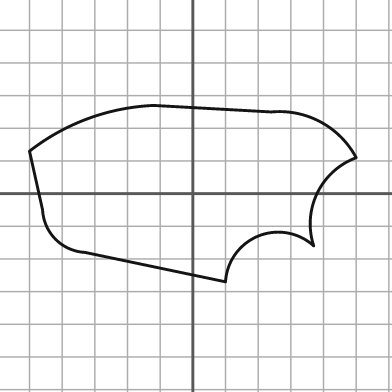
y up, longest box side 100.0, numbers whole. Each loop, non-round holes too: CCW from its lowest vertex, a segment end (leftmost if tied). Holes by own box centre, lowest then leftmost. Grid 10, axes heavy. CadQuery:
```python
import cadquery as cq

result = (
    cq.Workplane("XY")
    .moveTo(10.0, -27.0)
    .threePointArc((20.0, -13.0), (37.0, -16.0))
    .threePointArc((38.0, 0.0), (50.0, 11.0))
    .threePointArc((39.0, 22.0), (24.0, 25.0))
    .lineTo(-12.0, 27.0)
    .threePointArc((-32.0, 23.0), (-50.0, 13.0))
    .lineTo(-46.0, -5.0)
    .threePointArc((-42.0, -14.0), (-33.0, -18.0))
    .close()
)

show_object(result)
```